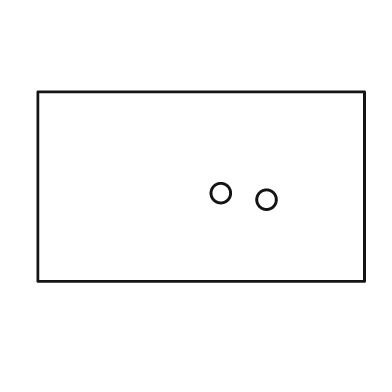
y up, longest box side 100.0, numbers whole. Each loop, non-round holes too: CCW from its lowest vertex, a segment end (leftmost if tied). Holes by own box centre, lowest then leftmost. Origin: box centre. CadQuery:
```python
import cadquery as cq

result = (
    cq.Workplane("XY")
    .moveTo(-50.0, -29.0)
    .lineTo(50.0, -29.0)
    .lineTo(50.0, 29.0)
    .lineTo(-50.0, 29.0)
    .close()
    .moveTo(20.0, -4.0)
    .circle(3.0)
    .moveTo(6.0, -2.0)
    .circle(3.0)
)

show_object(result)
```